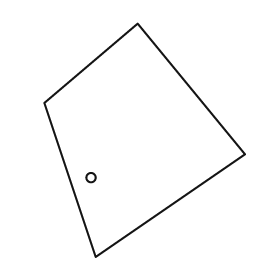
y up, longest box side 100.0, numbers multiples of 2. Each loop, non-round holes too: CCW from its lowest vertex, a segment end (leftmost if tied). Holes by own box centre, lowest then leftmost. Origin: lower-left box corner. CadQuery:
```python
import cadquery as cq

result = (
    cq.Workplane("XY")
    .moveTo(22.0, 0.0)
    .lineTo(86.0, 44.0)
    .lineTo(40.0, 100.0)
    .lineTo(0.0, 66.0)
    .close()
    .moveTo(20.0, 34.0)
    .circle(2.0)
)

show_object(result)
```